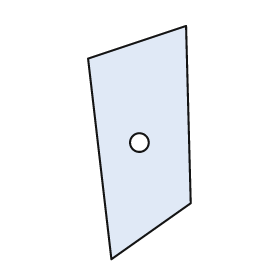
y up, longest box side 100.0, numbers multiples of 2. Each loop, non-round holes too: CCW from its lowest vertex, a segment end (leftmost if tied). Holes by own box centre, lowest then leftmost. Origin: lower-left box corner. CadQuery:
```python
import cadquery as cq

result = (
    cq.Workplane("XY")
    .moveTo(10.0, 0.0)
    .lineTo(44.0, 24.0)
    .lineTo(42.0, 100.0)
    .lineTo(0.0, 86.0)
    .close()
    .moveTo(22.0, 50.0)
    .circle(4.0)
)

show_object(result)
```